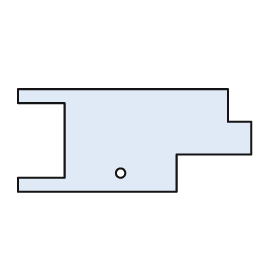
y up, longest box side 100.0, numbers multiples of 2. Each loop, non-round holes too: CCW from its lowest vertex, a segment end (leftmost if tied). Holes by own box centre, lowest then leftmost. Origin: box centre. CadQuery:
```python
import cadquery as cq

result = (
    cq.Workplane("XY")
    .moveTo(-50.0, -22.0)
    .lineTo(18.0, -22.0)
    .lineTo(18.0, -6.0)
    .lineTo(50.0, -6.0)
    .lineTo(50.0, 8.0)
    .lineTo(40.0, 8.0)
    .lineTo(40.0, 22.0)
    .lineTo(-50.0, 22.0)
    .lineTo(-50.0, 16.0)
    .lineTo(-30.0, 16.0)
    .lineTo(-30.0, -16.0)
    .lineTo(-50.0, -16.0)
    .close()
    .moveTo(-6.0, -14.0)
    .circle(2.0)
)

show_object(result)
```